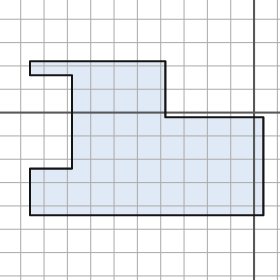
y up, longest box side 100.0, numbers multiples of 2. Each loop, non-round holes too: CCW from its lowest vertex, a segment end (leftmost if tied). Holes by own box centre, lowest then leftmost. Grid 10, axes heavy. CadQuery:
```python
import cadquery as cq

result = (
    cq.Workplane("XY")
    .moveTo(-96.0, -44.0)
    .lineTo(4.0, -44.0)
    .lineTo(4.0, -2.0)
    .lineTo(-38.0, -2.0)
    .lineTo(-38.0, 22.0)
    .lineTo(-96.0, 22.0)
    .lineTo(-96.0, 16.0)
    .lineTo(-78.0, 16.0)
    .lineTo(-78.0, -24.0)
    .lineTo(-96.0, -24.0)
    .close()
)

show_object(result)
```